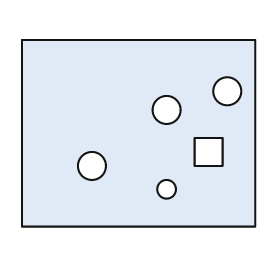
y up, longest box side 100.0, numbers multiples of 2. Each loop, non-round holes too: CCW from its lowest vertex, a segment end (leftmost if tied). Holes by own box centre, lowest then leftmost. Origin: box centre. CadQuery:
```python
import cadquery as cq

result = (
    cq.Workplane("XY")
    .moveTo(-50.0, -40.0)
    .lineTo(50.0, -40.0)
    .lineTo(50.0, 40.0)
    .lineTo(-50.0, 40.0)
    .close()
    .moveTo(12.0, -24.0)
    .circle(4.0)
    .moveTo(-20.0, -14.0)
    .circle(6.0)
    .moveTo(24.0, -14.0)
    .lineTo(36.0, -14.0)
    .lineTo(36.0, -2.0)
    .lineTo(24.0, -2.0)
    .close()
    .moveTo(12.0, 10.0)
    .circle(6.0)
    .moveTo(38.0, 18.0)
    .circle(6.0)
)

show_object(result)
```